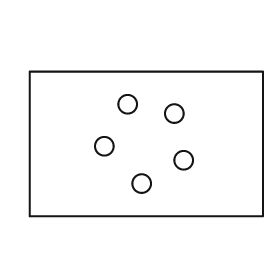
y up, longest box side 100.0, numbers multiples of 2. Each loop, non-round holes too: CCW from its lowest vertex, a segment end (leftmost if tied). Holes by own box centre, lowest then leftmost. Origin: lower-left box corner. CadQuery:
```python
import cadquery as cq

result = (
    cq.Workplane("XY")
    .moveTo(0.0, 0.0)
    .lineTo(100.0, 0.0)
    .lineTo(100.0, 62.0)
    .lineTo(0.0, 62.0)
    .close()
    .moveTo(48.0, 14.0)
    .circle(4.0)
    .moveTo(66.0, 24.0)
    .circle(4.0)
    .moveTo(32.0, 30.0)
    .circle(4.0)
    .moveTo(62.0, 44.0)
    .circle(4.0)
    .moveTo(42.0, 48.0)
    .circle(4.0)
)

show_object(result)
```